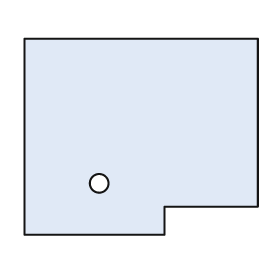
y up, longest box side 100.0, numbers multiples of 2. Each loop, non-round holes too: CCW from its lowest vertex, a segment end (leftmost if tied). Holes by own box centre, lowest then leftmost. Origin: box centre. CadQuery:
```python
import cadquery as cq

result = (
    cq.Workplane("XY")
    .moveTo(-50.0, -42.0)
    .lineTo(10.0, -42.0)
    .lineTo(10.0, -30.0)
    .lineTo(50.0, -30.0)
    .lineTo(50.0, 42.0)
    .lineTo(-50.0, 42.0)
    .close()
    .moveTo(-18.0, -20.0)
    .circle(4.0)
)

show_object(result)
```